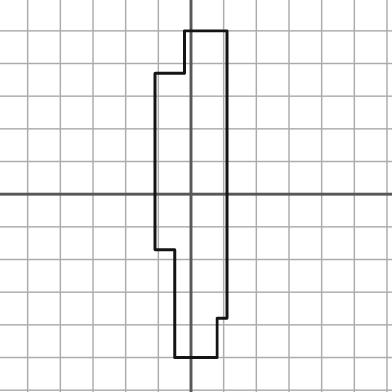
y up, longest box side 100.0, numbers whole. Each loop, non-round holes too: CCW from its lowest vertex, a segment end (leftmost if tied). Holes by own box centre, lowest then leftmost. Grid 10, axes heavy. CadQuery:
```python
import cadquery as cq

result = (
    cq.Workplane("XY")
    .moveTo(-5.0, -50.0)
    .lineTo(8.0, -50.0)
    .lineTo(8.0, -38.0)
    .lineTo(11.0, -38.0)
    .lineTo(11.0, 50.0)
    .lineTo(-2.0, 50.0)
    .lineTo(-2.0, 37.0)
    .lineTo(-11.0, 37.0)
    .lineTo(-11.0, -17.0)
    .lineTo(-5.0, -17.0)
    .close()
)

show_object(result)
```